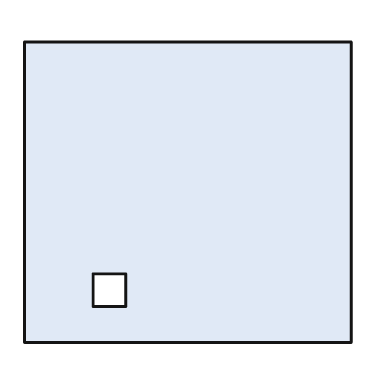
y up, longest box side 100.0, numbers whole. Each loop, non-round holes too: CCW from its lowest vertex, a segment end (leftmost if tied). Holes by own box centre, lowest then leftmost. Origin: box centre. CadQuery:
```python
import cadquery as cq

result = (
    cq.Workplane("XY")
    .moveTo(-50.0, -46.0)
    .lineTo(50.0, -46.0)
    .lineTo(50.0, 46.0)
    .lineTo(-50.0, 46.0)
    .close()
    .moveTo(-29.0, -35.0)
    .lineTo(-19.0, -35.0)
    .lineTo(-19.0, -25.0)
    .lineTo(-29.0, -25.0)
    .close()
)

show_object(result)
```